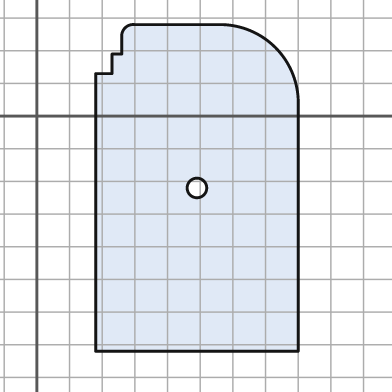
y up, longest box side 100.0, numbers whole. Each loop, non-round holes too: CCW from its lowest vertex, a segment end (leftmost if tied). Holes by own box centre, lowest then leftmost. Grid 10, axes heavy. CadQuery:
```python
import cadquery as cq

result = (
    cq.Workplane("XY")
    .moveTo(18.0, -72.0)
    .lineTo(80.0, -72.0)
    .lineTo(80.0, 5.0)
    .threePointArc((73.0, 21.0), (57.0, 28.0))
    .lineTo(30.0, 28.0)
    .threePointArc((27.0, 27.0), (26.0, 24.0))
    .lineTo(26.0, 19.0)
    .lineTo(23.0, 19.0)
    .lineTo(23.0, 13.0)
    .lineTo(18.0, 13.0)
    .close()
    .moveTo(49.0, -22.0)
    .circle(3.0)
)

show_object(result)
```